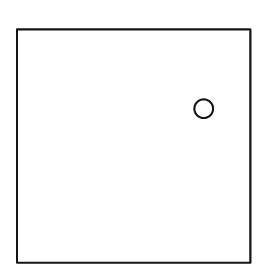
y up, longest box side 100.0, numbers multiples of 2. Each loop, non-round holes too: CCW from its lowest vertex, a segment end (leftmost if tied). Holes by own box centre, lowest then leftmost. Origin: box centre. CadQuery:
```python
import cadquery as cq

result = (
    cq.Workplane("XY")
    .moveTo(-50.0, -50.0)
    .lineTo(50.0, -50.0)
    .lineTo(50.0, 50.0)
    .lineTo(-50.0, 50.0)
    .close()
    .moveTo(30.0, 16.0)
    .circle(4.0)
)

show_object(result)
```